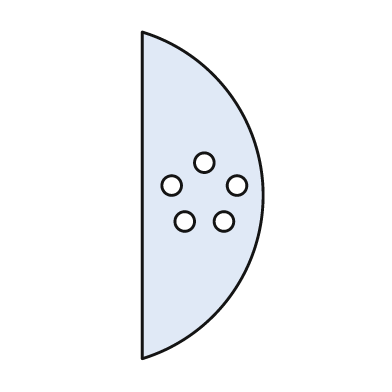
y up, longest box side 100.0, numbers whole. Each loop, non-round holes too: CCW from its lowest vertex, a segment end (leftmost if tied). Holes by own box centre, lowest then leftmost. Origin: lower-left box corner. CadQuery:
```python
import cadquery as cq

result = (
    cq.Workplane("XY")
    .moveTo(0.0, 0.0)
    .threePointArc((37.0, 50.0), (0.0, 100.0))
    .close()
    .moveTo(13.0, 42.0)
    .circle(3.0)
    .moveTo(25.0, 42.0)
    .circle(3.0)
    .moveTo(9.0, 53.0)
    .circle(3.0)
    .moveTo(29.0, 53.0)
    .circle(3.0)
    .moveTo(19.0, 60.0)
    .circle(3.0)
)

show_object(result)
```